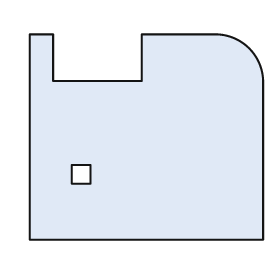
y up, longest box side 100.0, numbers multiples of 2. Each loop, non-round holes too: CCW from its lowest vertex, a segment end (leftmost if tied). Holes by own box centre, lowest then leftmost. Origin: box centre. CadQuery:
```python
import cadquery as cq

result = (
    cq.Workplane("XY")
    .moveTo(-50.0, -44.0)
    .lineTo(50.0, -44.0)
    .lineTo(50.0, 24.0)
    .threePointArc((44.0, 38.0), (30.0, 44.0))
    .lineTo(-2.0, 44.0)
    .lineTo(-2.0, 24.0)
    .lineTo(-40.0, 24.0)
    .lineTo(-40.0, 44.0)
    .lineTo(-50.0, 44.0)
    .close()
    .moveTo(-32.0, -20.0)
    .lineTo(-24.0, -20.0)
    .lineTo(-24.0, -12.0)
    .lineTo(-32.0, -12.0)
    .close()
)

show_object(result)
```